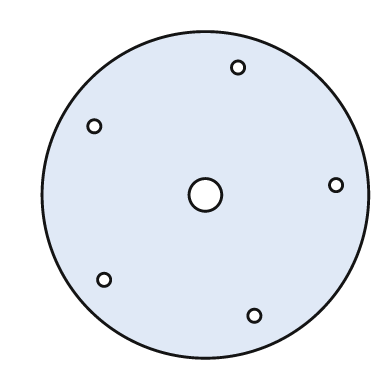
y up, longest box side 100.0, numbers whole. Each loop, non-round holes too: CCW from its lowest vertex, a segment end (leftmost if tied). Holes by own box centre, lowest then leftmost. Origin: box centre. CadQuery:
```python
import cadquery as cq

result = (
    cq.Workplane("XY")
    .moveTo(0.0, 0.0)
    .circle(50.0)
    .moveTo(15.0, -37.0)
    .circle(2.0)
    .moveTo(-31.0, -26.0)
    .circle(2.0)
    .moveTo(0.0, 0.0)
    .circle(5.0)
    .moveTo(40.0, 3.0)
    .circle(2.0)
    .moveTo(-34.0, 21.0)
    .circle(2.0)
    .moveTo(10.0, 39.0)
    .circle(2.0)
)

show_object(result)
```